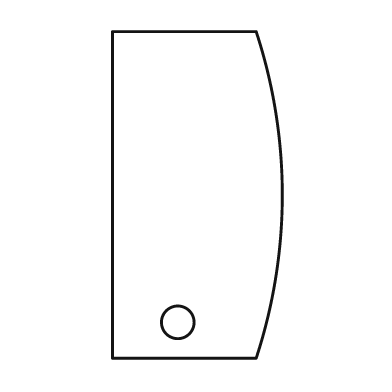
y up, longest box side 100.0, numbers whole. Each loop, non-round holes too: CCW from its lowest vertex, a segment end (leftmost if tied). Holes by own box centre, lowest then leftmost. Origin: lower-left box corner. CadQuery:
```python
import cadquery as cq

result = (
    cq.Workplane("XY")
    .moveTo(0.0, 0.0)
    .lineTo(44.0, 0.0)
    .threePointArc((52.0, 50.0), (44.0, 100.0))
    .lineTo(0.0, 100.0)
    .close()
    .moveTo(20.0, 11.0)
    .circle(5.0)
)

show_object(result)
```